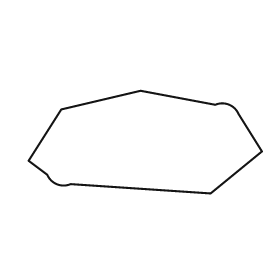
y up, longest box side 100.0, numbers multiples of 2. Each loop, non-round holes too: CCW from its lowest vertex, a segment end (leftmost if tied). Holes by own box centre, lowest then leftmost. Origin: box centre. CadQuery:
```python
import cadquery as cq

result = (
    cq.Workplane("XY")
    .moveTo(28.0, -22.0)
    .lineTo(50.0, -4.0)
    .lineTo(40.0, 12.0)
    .threePointArc((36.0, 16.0), (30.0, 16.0))
    .lineTo(-2.0, 22.0)
    .lineTo(-36.0, 14.0)
    .lineTo(-50.0, -8.0)
    .lineTo(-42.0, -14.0)
    .threePointArc((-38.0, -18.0), (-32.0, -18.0))
    .close()
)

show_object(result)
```